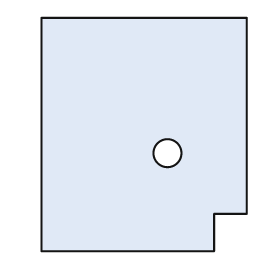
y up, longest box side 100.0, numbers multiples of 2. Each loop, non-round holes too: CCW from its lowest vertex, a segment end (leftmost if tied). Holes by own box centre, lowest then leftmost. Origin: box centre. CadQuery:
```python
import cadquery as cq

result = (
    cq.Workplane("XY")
    .moveTo(-44.0, -50.0)
    .lineTo(30.0, -50.0)
    .lineTo(30.0, -34.0)
    .lineTo(44.0, -34.0)
    .lineTo(44.0, 50.0)
    .lineTo(-44.0, 50.0)
    .close()
    .moveTo(10.0, -8.0)
    .circle(6.0)
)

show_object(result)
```